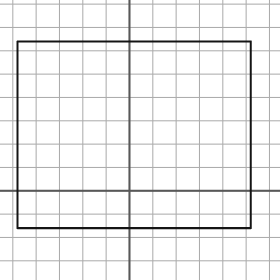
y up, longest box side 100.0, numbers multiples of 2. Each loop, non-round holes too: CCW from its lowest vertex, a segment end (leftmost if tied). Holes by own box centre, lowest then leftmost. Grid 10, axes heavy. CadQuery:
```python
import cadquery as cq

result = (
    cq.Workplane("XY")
    .moveTo(-48.0, -16.0)
    .lineTo(52.0, -16.0)
    .lineTo(52.0, 64.0)
    .lineTo(-48.0, 64.0)
    .close()
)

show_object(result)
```